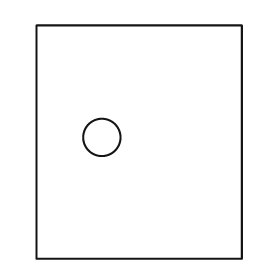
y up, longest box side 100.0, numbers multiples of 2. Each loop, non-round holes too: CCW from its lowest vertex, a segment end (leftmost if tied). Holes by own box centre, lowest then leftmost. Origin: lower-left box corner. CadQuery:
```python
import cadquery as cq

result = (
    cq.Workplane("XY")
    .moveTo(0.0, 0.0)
    .lineTo(88.0, 0.0)
    .lineTo(88.0, 100.0)
    .lineTo(0.0, 100.0)
    .close()
    .moveTo(28.0, 52.0)
    .circle(8.0)
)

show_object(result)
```